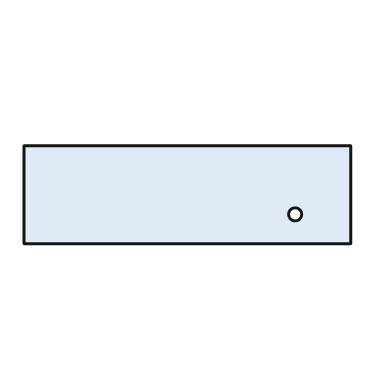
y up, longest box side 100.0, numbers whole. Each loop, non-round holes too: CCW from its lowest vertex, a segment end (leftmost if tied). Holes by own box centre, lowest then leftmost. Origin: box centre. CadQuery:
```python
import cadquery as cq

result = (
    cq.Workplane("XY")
    .moveTo(-50.0, -15.0)
    .lineTo(50.0, -15.0)
    .lineTo(50.0, 15.0)
    .lineTo(-50.0, 15.0)
    .close()
    .moveTo(33.0, -6.0)
    .circle(2.0)
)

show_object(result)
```